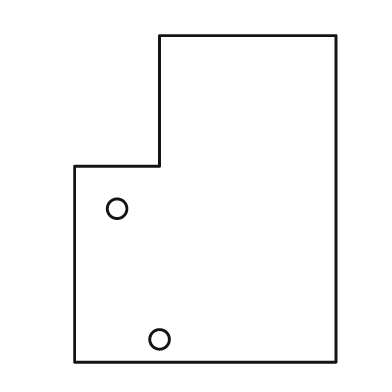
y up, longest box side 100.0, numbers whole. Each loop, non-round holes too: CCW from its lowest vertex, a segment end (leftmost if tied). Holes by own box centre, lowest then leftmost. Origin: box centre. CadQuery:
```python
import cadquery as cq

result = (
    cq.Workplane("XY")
    .moveTo(-40.0, -50.0)
    .lineTo(40.0, -50.0)
    .lineTo(40.0, 50.0)
    .lineTo(-14.0, 50.0)
    .lineTo(-14.0, 10.0)
    .lineTo(-40.0, 10.0)
    .close()
    .moveTo(-14.0, -43.0)
    .circle(3.0)
    .moveTo(-27.0, -3.0)
    .circle(3.0)
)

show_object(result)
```